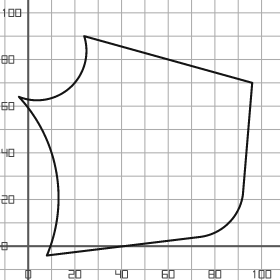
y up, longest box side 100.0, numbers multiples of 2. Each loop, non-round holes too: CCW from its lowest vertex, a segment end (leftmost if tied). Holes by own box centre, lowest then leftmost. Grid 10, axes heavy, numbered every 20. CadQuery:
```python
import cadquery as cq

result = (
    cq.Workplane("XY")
    .moveTo(8.0, -4.0)
    .lineTo(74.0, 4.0)
    .threePointArc((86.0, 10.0), (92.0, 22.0))
    .lineTo(96.0, 70.0)
    .lineTo(24.0, 90.0)
    .threePointArc((18.0, 68.0), (-4.0, 64.0))
    .threePointArc((12.0, 32.0), (8.0, -4.0))
    .close()
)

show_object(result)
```